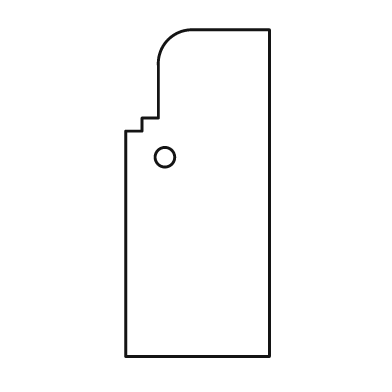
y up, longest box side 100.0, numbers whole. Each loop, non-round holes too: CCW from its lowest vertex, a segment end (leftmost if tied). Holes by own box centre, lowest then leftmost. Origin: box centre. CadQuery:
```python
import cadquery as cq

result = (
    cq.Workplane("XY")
    .moveTo(-22.0, -50.0)
    .lineTo(22.0, -50.0)
    .lineTo(22.0, 50.0)
    .lineTo(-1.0, 50.0)
    .threePointArc((-9.0, 47.0), (-12.0, 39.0))
    .lineTo(-12.0, 23.0)
    .lineTo(-17.0, 23.0)
    .lineTo(-17.0, 19.0)
    .lineTo(-22.0, 19.0)
    .close()
    .moveTo(-10.0, 11.0)
    .circle(3.0)
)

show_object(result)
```